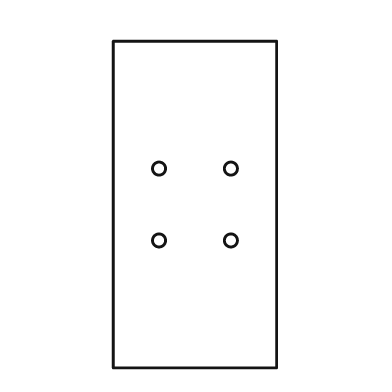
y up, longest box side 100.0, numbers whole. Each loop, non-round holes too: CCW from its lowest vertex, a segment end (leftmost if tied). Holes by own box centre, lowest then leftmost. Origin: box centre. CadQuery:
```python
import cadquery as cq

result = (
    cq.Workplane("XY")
    .moveTo(-25.0, -50.0)
    .lineTo(25.0, -50.0)
    .lineTo(25.0, 50.0)
    .lineTo(-25.0, 50.0)
    .close()
    .moveTo(-11.0, -11.0)
    .circle(2.0)
    .moveTo(11.0, -11.0)
    .circle(2.0)
    .moveTo(-11.0, 11.0)
    .circle(2.0)
    .moveTo(11.0, 11.0)
    .circle(2.0)
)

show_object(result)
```